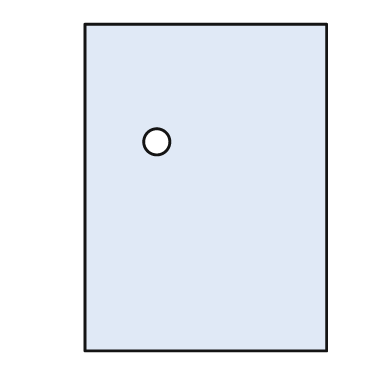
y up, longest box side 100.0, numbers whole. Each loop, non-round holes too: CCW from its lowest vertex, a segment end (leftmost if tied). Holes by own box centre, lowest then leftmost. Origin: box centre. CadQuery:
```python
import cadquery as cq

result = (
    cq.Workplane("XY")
    .moveTo(-37.0, -50.0)
    .lineTo(37.0, -50.0)
    .lineTo(37.0, 50.0)
    .lineTo(-37.0, 50.0)
    .close()
    .moveTo(-15.0, 14.0)
    .circle(4.0)
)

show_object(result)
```